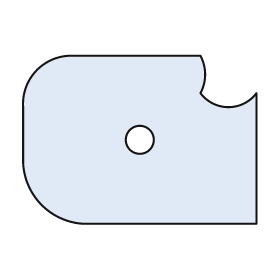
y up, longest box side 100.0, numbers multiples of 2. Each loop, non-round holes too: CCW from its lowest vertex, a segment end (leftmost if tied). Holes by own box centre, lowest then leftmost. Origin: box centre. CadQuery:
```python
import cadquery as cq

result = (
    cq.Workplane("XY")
    .moveTo(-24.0, -36.0)
    .lineTo(50.0, -36.0)
    .lineTo(50.0, 20.0)
    .threePointArc((38.0, 14.0), (26.0, 20.0))
    .threePointArc((28.0, 28.0), (26.0, 36.0))
    .lineTo(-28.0, 36.0)
    .threePointArc((-44.0, 30.0), (-50.0, 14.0))
    .lineTo(-50.0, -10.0)
    .threePointArc((-42.0, -28.0), (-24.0, -36.0))
    .close()
    .moveTo(0.0, 0.0)
    .circle(6.0)
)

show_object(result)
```